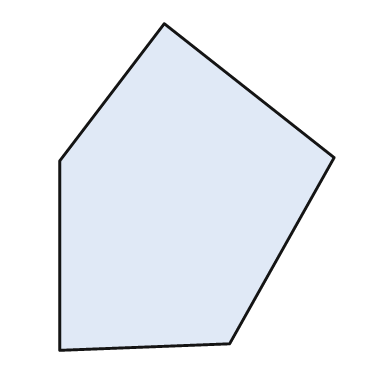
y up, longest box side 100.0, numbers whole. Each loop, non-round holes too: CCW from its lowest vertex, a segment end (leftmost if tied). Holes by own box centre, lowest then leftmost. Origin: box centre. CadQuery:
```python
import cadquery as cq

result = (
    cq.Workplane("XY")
    .moveTo(-42.0, -50.0)
    .lineTo(10.0, -48.0)
    .lineTo(42.0, 9.0)
    .lineTo(-10.0, 50.0)
    .lineTo(-42.0, 8.0)
    .close()
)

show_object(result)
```